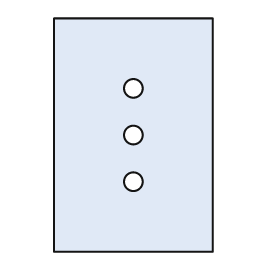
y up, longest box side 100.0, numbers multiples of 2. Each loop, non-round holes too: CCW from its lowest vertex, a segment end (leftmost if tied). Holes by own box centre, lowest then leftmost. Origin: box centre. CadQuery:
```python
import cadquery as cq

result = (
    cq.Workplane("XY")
    .moveTo(-34.0, -50.0)
    .lineTo(34.0, -50.0)
    .lineTo(34.0, 50.0)
    .lineTo(-34.0, 50.0)
    .close()
    .moveTo(0.0, -20.0)
    .circle(4.0)
    .moveTo(0.0, 0.0)
    .circle(4.0)
    .moveTo(0.0, 20.0)
    .circle(4.0)
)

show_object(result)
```